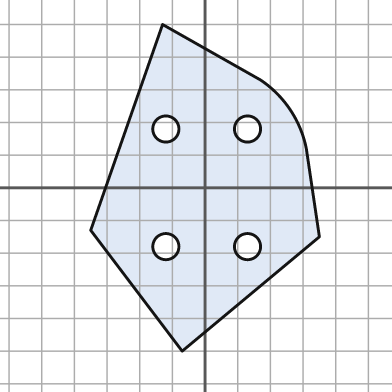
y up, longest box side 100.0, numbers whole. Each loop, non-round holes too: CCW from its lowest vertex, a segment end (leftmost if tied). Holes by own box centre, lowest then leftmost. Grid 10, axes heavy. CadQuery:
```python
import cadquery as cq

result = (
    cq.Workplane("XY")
    .moveTo(-7.0, -50.0)
    .lineTo(35.0, -15.0)
    .lineTo(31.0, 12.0)
    .threePointArc((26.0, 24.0), (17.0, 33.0))
    .lineTo(-13.0, 50.0)
    .lineTo(-35.0, -13.0)
    .close()
    .moveTo(-12.0, -18.0)
    .circle(4.0)
    .moveTo(13.0, -18.0)
    .circle(4.0)
    .moveTo(-12.0, 18.0)
    .circle(4.0)
    .moveTo(13.0, 18.0)
    .circle(4.0)
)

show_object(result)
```